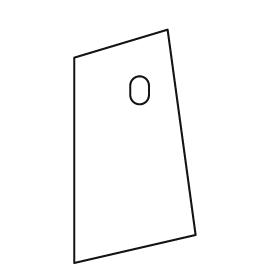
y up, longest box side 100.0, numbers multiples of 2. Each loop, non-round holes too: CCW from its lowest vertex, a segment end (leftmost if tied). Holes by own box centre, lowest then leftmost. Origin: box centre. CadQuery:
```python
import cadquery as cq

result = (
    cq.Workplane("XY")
    .moveTo(-26.0, -50.0)
    .lineTo(26.0, -38.0)
    .lineTo(14.0, 50.0)
    .lineTo(-26.0, 38.0)
    .close()
    .moveTo(-2.0, 22.0)
    .threePointArc((2.0, 18.0), (6.0, 22.0))
    .lineTo(6.0, 26.0)
    .threePointArc((2.0, 30.0), (-2.0, 26.0))
    .close()
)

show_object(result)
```